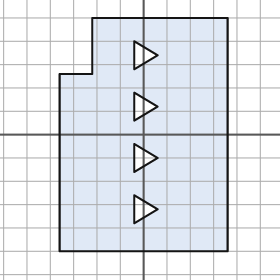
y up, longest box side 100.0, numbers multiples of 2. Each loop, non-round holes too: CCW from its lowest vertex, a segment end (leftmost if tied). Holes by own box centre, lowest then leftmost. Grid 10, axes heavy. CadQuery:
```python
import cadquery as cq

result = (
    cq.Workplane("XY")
    .moveTo(-36.0, -50.0)
    .lineTo(36.0, -50.0)
    .lineTo(36.0, 50.0)
    .lineTo(-22.0, 50.0)
    .lineTo(-22.0, 26.0)
    .lineTo(-36.0, 26.0)
    .close()
    .moveTo(-4.0, -38.0)
    .lineTo(6.0, -32.0)
    .lineTo(-4.0, -26.0)
    .close()
    .moveTo(-4.0, -16.0)
    .lineTo(6.0, -10.0)
    .lineTo(-4.0, -4.0)
    .close()
    .moveTo(-4.0, 6.0)
    .lineTo(6.0, 12.0)
    .lineTo(-4.0, 18.0)
    .close()
    .moveTo(-4.0, 28.0)
    .lineTo(6.0, 34.0)
    .lineTo(-4.0, 40.0)
    .close()
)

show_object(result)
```